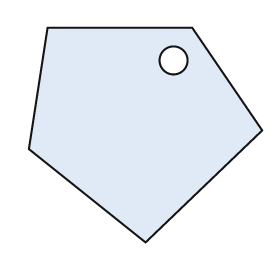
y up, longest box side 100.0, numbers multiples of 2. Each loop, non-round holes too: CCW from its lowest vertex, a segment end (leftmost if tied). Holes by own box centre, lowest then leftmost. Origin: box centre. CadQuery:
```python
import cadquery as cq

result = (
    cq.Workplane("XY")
    .moveTo(0.0, -46.0)
    .lineTo(50.0, 2.0)
    .lineTo(20.0, 46.0)
    .lineTo(-42.0, 46.0)
    .lineTo(-50.0, -6.0)
    .close()
    .moveTo(12.0, 32.0)
    .circle(6.0)
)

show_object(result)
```